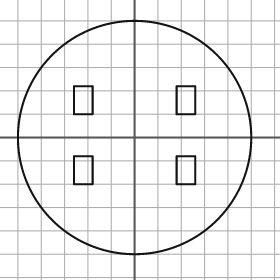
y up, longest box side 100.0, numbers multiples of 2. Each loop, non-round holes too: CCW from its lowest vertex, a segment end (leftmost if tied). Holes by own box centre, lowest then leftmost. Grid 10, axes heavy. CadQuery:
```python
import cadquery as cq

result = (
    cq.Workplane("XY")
    .moveTo(0.0, 0.0)
    .circle(50.0)
    .moveTo(-26.0, -20.0)
    .lineTo(-18.0, -20.0)
    .lineTo(-18.0, -8.0)
    .lineTo(-26.0, -8.0)
    .close()
    .moveTo(18.0, -20.0)
    .lineTo(26.0, -20.0)
    .lineTo(26.0, -8.0)
    .lineTo(18.0, -8.0)
    .close()
    .moveTo(-26.0, 10.0)
    .lineTo(-18.0, 10.0)
    .lineTo(-18.0, 22.0)
    .lineTo(-26.0, 22.0)
    .close()
    .moveTo(18.0, 10.0)
    .lineTo(26.0, 10.0)
    .lineTo(26.0, 22.0)
    .lineTo(18.0, 22.0)
    .close()
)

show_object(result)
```